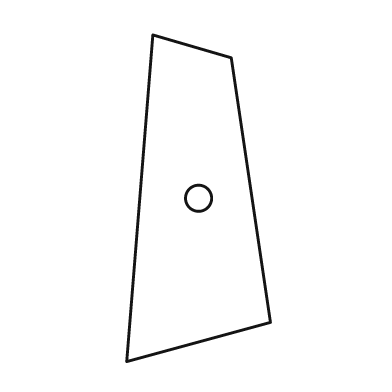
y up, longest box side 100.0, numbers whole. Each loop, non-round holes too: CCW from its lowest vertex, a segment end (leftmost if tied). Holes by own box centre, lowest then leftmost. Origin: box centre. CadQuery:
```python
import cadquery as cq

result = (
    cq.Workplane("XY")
    .moveTo(-22.0, -50.0)
    .lineTo(22.0, -38.0)
    .lineTo(10.0, 43.0)
    .lineTo(-14.0, 50.0)
    .close()
    .moveTo(0.0, 0.0)
    .circle(4.0)
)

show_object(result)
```